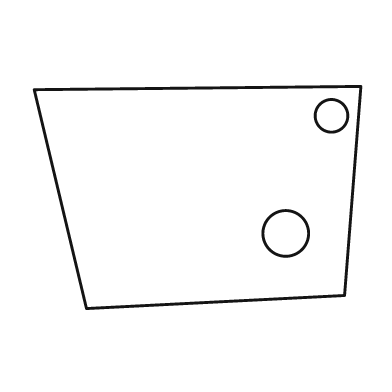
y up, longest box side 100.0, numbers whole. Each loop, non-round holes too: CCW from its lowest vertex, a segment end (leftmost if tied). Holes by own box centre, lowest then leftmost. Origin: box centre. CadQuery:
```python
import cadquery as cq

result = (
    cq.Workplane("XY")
    .moveTo(-34.0, -34.0)
    .lineTo(45.0, -30.0)
    .lineTo(50.0, 34.0)
    .lineTo(-50.0, 33.0)
    .close()
    .moveTo(27.0, -11.0)
    .circle(7.0)
    .moveTo(41.0, 25.0)
    .circle(5.0)
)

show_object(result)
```